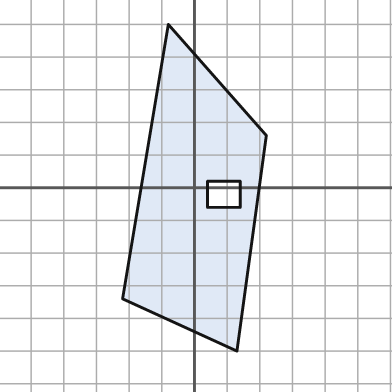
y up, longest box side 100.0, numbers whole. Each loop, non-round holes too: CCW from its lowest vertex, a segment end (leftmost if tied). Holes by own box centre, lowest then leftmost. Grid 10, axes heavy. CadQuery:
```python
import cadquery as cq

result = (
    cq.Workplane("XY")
    .moveTo(13.0, -50.0)
    .lineTo(22.0, 16.0)
    .lineTo(-8.0, 50.0)
    .lineTo(-22.0, -34.0)
    .close()
    .moveTo(4.0, -6.0)
    .lineTo(14.0, -6.0)
    .lineTo(14.0, 2.0)
    .lineTo(4.0, 2.0)
    .close()
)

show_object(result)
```